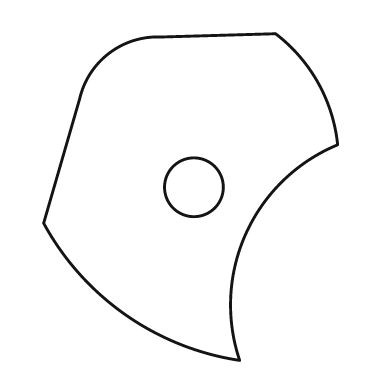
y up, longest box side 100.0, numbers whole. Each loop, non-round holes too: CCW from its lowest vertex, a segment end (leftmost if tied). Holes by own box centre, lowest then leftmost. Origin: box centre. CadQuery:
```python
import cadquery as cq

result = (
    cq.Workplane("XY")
    .moveTo(15.0, -50.0)
    .threePointArc((17.0, -11.0), (45.0, 16.0))
    .threePointArc((39.0, 35.0), (26.0, 50.0))
    .lineTo(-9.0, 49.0)
    .threePointArc((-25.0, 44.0), (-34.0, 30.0))
    .lineTo(-45.0, -8.0)
    .threePointArc((-20.0, -36.0), (15.0, -50.0))
    .close()
    .moveTo(1.0, 3.0)
    .circle(9.0)
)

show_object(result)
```